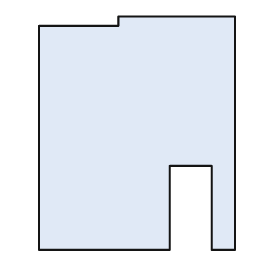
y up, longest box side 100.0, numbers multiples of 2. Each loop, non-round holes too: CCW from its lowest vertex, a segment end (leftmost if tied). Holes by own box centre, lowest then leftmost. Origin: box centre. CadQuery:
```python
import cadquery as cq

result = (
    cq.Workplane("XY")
    .moveTo(-42.0, -50.0)
    .lineTo(14.0, -50.0)
    .lineTo(14.0, -14.0)
    .lineTo(32.0, -14.0)
    .lineTo(32.0, -50.0)
    .lineTo(42.0, -50.0)
    .lineTo(42.0, 50.0)
    .lineTo(-8.0, 50.0)
    .lineTo(-8.0, 46.0)
    .lineTo(-42.0, 46.0)
    .close()
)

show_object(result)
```